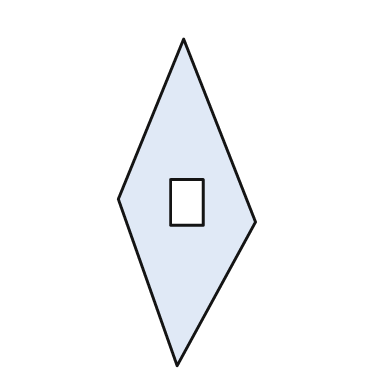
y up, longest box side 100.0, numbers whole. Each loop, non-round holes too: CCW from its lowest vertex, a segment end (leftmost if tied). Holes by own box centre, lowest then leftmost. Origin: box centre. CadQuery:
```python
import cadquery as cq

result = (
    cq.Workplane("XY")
    .moveTo(-3.0, -50.0)
    .lineTo(21.0, -6.0)
    .lineTo(-1.0, 50.0)
    .lineTo(-21.0, 1.0)
    .close()
    .moveTo(-5.0, -7.0)
    .lineTo(5.0, -7.0)
    .lineTo(5.0, 7.0)
    .lineTo(-5.0, 7.0)
    .close()
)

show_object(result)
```